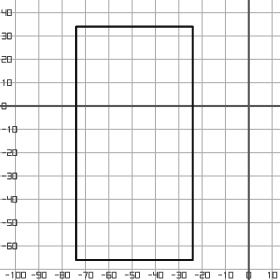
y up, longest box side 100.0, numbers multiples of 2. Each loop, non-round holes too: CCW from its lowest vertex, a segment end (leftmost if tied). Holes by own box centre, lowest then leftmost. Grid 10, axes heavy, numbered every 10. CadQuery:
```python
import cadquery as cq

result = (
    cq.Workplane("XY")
    .moveTo(-74.0, -66.0)
    .lineTo(-24.0, -66.0)
    .lineTo(-24.0, 34.0)
    .lineTo(-74.0, 34.0)
    .close()
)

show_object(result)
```